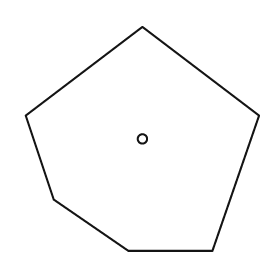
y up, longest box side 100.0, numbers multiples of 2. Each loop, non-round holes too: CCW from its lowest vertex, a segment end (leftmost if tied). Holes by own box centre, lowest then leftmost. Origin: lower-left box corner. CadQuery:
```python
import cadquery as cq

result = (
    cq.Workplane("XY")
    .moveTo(44.0, 0.0)
    .lineTo(80.0, 0.0)
    .lineTo(100.0, 58.0)
    .lineTo(50.0, 96.0)
    .lineTo(0.0, 58.0)
    .lineTo(12.0, 22.0)
    .close()
    .moveTo(50.0, 48.0)
    .circle(2.0)
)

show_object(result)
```